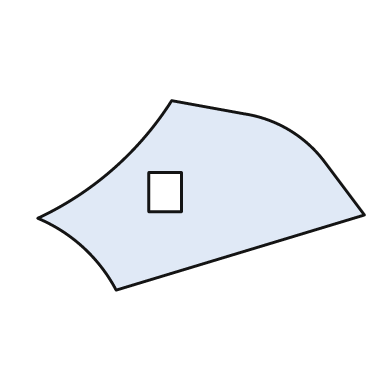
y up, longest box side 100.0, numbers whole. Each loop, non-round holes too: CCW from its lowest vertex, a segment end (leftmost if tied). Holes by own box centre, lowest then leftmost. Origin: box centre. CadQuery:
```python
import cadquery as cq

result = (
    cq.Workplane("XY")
    .moveTo(-26.0, -29.0)
    .lineTo(50.0, -6.0)
    .lineTo(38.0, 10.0)
    .threePointArc((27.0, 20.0), (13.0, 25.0))
    .lineTo(-9.0, 29.0)
    .threePointArc((-27.0, 8.0), (-50.0, -7.0))
    .threePointArc((-36.0, -16.0), (-26.0, -29.0))
    .close()
    .moveTo(-16.0, -5.0)
    .lineTo(-6.0, -5.0)
    .lineTo(-6.0, 7.0)
    .lineTo(-16.0, 7.0)
    .close()
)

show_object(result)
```